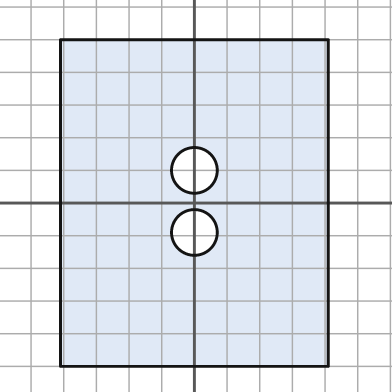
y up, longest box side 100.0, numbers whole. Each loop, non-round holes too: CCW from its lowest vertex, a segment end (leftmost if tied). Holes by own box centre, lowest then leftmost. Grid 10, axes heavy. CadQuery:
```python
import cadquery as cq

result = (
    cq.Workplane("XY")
    .moveTo(-41.0, -50.0)
    .lineTo(41.0, -50.0)
    .lineTo(41.0, 50.0)
    .lineTo(-41.0, 50.0)
    .close()
    .moveTo(0.0, -9.0)
    .circle(7.0)
    .moveTo(0.0, 10.0)
    .circle(7.0)
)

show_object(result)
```